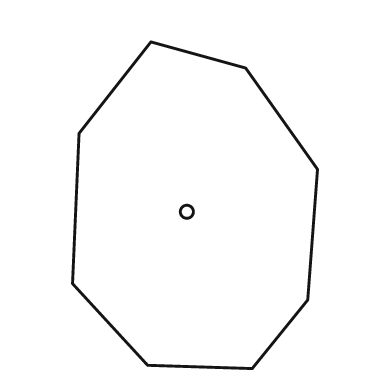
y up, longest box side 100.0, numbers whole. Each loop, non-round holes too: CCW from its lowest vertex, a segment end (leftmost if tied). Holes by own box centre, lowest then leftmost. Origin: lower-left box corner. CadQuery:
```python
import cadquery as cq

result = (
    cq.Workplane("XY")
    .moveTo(55.0, 0.0)
    .lineTo(72.0, 21.0)
    .lineTo(75.0, 61.0)
    .lineTo(53.0, 92.0)
    .lineTo(24.0, 100.0)
    .lineTo(2.0, 72.0)
    .lineTo(0.0, 26.0)
    .lineTo(23.0, 1.0)
    .close()
    .moveTo(35.0, 48.0)
    .circle(2.0)
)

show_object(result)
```